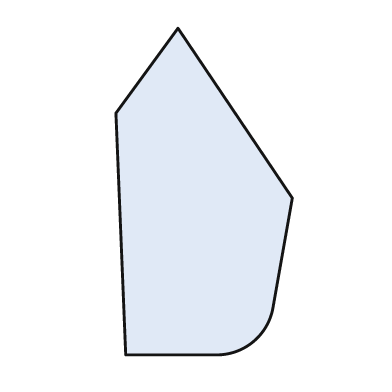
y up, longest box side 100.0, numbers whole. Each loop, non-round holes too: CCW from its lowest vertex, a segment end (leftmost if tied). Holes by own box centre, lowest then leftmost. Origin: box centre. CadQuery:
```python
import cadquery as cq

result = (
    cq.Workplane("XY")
    .moveTo(-24.0, -50.0)
    .lineTo(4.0, -50.0)
    .threePointArc((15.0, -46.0), (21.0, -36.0))
    .lineTo(27.0, -2.0)
    .lineTo(-8.0, 50.0)
    .lineTo(-27.0, 24.0)
    .close()
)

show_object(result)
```